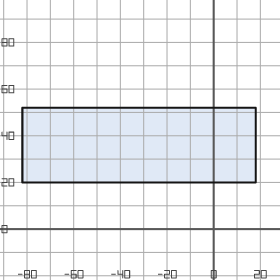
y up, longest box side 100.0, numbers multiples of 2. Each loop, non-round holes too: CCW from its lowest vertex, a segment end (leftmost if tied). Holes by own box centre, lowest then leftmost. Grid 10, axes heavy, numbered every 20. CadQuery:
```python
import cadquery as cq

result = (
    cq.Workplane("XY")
    .moveTo(-82.0, 20.0)
    .lineTo(18.0, 20.0)
    .lineTo(18.0, 52.0)
    .lineTo(-82.0, 52.0)
    .close()
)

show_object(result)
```